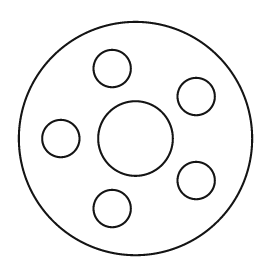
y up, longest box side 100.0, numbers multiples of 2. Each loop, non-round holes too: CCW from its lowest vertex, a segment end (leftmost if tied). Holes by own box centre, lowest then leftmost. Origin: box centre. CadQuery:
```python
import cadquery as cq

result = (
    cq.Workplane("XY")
    .moveTo(0.0, 0.0)
    .circle(50.0)
    .moveTo(-10.0, -30.0)
    .circle(8.0)
    .moveTo(26.0, -18.0)
    .circle(8.0)
    .moveTo(-32.0, 0.0)
    .circle(8.0)
    .moveTo(0.0, 0.0)
    .circle(16.0)
    .moveTo(26.0, 18.0)
    .circle(8.0)
    .moveTo(-10.0, 30.0)
    .circle(8.0)
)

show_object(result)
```